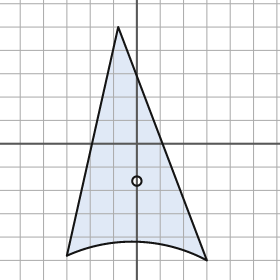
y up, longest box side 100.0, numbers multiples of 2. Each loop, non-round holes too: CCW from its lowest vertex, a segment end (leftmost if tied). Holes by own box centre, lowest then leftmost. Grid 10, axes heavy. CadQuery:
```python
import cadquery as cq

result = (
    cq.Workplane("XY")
    .moveTo(30.0, -50.0)
    .lineTo(-8.0, 50.0)
    .lineTo(-30.0, -48.0)
    .threePointArc((0.0, -42.0), (30.0, -50.0))
    .close()
    .moveTo(0.0, -16.0)
    .circle(2.0)
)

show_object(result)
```